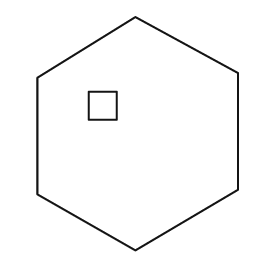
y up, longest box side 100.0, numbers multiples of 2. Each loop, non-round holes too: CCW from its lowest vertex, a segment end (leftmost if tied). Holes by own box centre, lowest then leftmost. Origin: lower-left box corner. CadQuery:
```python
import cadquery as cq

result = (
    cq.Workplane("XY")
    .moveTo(42.0, 0.0)
    .lineTo(86.0, 26.0)
    .lineTo(86.0, 76.0)
    .lineTo(42.0, 100.0)
    .lineTo(0.0, 74.0)
    .lineTo(0.0, 24.0)
    .close()
    .moveTo(22.0, 56.0)
    .lineTo(34.0, 56.0)
    .lineTo(34.0, 68.0)
    .lineTo(22.0, 68.0)
    .close()
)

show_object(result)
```